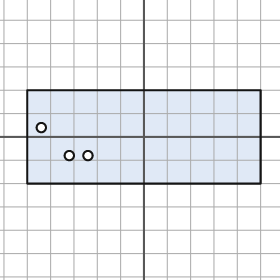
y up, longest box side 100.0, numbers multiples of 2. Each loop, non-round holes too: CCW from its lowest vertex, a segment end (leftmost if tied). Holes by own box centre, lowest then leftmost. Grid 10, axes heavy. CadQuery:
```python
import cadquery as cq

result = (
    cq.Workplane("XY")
    .moveTo(-50.0, -20.0)
    .lineTo(50.0, -20.0)
    .lineTo(50.0, 20.0)
    .lineTo(-50.0, 20.0)
    .close()
    .moveTo(-32.0, -8.0)
    .circle(2.0)
    .moveTo(-24.0, -8.0)
    .circle(2.0)
    .moveTo(-44.0, 4.0)
    .circle(2.0)
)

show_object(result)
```